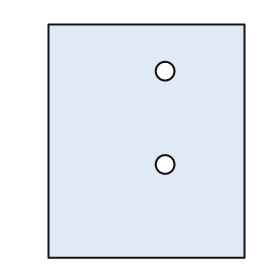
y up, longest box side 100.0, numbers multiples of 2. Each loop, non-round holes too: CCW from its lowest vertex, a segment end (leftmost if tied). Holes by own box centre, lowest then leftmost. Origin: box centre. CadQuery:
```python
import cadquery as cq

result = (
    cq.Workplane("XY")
    .moveTo(-42.0, -50.0)
    .lineTo(42.0, -50.0)
    .lineTo(42.0, 50.0)
    .lineTo(-42.0, 50.0)
    .close()
    .moveTo(8.0, -10.0)
    .circle(4.0)
    .moveTo(8.0, 30.0)
    .circle(4.0)
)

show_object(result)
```